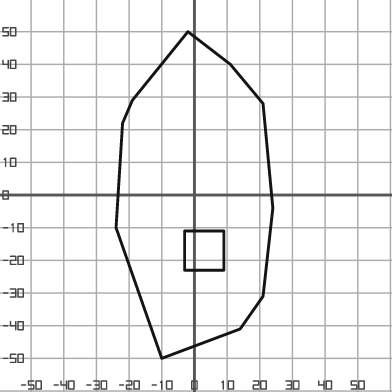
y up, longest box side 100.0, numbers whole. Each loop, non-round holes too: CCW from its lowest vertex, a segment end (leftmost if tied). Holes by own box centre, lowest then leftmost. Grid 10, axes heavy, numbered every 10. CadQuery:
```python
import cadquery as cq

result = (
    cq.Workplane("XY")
    .moveTo(-10.0, -50.0)
    .lineTo(14.0, -41.0)
    .lineTo(21.0, -31.0)
    .lineTo(24.0, -4.0)
    .lineTo(21.0, 28.0)
    .lineTo(11.0, 40.0)
    .lineTo(-2.0, 50.0)
    .lineTo(-19.0, 29.0)
    .lineTo(-22.0, 22.0)
    .lineTo(-24.0, -10.0)
    .close()
    .moveTo(-3.0, -23.0)
    .lineTo(9.0, -23.0)
    .lineTo(9.0, -11.0)
    .lineTo(-3.0, -11.0)
    .close()
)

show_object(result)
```